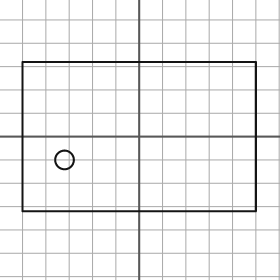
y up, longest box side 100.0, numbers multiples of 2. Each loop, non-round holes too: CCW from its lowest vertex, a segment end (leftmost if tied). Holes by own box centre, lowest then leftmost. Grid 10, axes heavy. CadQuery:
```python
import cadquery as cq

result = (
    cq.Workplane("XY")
    .moveTo(-50.0, -32.0)
    .lineTo(50.0, -32.0)
    .lineTo(50.0, 32.0)
    .lineTo(-50.0, 32.0)
    .close()
    .moveTo(-32.0, -10.0)
    .circle(4.0)
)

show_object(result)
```